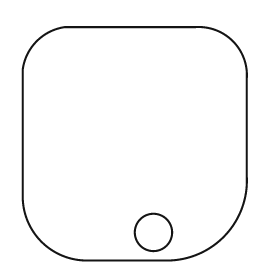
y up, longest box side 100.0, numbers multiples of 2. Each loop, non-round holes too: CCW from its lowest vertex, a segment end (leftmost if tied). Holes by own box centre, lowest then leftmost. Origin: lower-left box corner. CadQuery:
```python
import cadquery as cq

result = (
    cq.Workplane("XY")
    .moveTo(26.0, 0.0)
    .lineTo(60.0, 0.0)
    .threePointArc((86.0, 10.0), (96.0, 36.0))
    .lineTo(96.0, 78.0)
    .threePointArc((90.0, 94.0), (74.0, 100.0))
    .lineTo(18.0, 100.0)
    .threePointArc((6.0, 94.0), (0.0, 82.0))
    .lineTo(0.0, 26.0)
    .threePointArc((8.0, 8.0), (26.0, 0.0))
    .close()
    .moveTo(56.0, 12.0)
    .circle(8.0)
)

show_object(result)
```